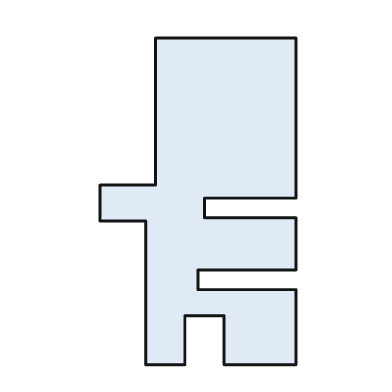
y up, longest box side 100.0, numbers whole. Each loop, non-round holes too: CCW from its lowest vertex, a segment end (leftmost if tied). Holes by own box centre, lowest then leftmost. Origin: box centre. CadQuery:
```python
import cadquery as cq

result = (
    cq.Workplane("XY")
    .moveTo(-16.0, -50.0)
    .lineTo(-4.0, -50.0)
    .lineTo(-4.0, -35.0)
    .lineTo(8.0, -35.0)
    .lineTo(8.0, -50.0)
    .lineTo(30.0, -50.0)
    .lineTo(30.0, -27.0)
    .lineTo(0.0, -27.0)
    .lineTo(0.0, -21.0)
    .lineTo(30.0, -21.0)
    .lineTo(30.0, -5.0)
    .lineTo(2.0, -5.0)
    .lineTo(2.0, 1.0)
    .lineTo(30.0, 1.0)
    .lineTo(30.0, 50.0)
    .lineTo(-13.0, 50.0)
    .lineTo(-13.0, 5.0)
    .lineTo(-30.0, 5.0)
    .lineTo(-30.0, -6.0)
    .lineTo(-16.0, -6.0)
    .close()
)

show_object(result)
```